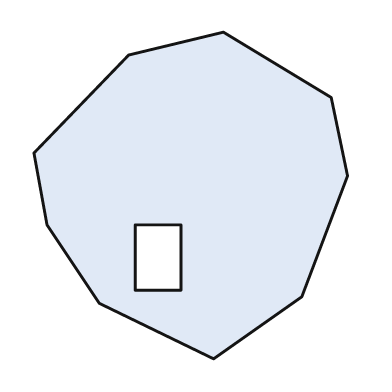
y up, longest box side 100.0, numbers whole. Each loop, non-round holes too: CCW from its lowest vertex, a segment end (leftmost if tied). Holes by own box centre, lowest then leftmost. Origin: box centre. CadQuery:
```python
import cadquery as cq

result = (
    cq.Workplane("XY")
    .moveTo(7.0, -50.0)
    .lineTo(34.0, -31.0)
    .lineTo(48.0, 6.0)
    .lineTo(43.0, 30.0)
    .lineTo(10.0, 50.0)
    .lineTo(-19.0, 43.0)
    .lineTo(-48.0, 13.0)
    .lineTo(-44.0, -9.0)
    .lineTo(-28.0, -33.0)
    .close()
    .moveTo(-17.0, -29.0)
    .lineTo(-3.0, -29.0)
    .lineTo(-3.0, -9.0)
    .lineTo(-17.0, -9.0)
    .close()
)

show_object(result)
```